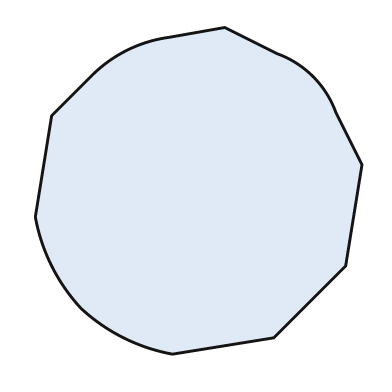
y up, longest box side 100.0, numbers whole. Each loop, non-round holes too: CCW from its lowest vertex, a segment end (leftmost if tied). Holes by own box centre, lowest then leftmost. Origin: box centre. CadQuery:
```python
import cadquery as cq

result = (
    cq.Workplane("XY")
    .moveTo(-8.0, -50.0)
    .lineTo(23.0, -45.0)
    .lineTo(45.0, -23.0)
    .lineTo(50.0, 8.0)
    .lineTo(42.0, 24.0)
    .threePointArc((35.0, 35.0), (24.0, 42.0))
    .lineTo(8.0, 50.0)
    .lineTo(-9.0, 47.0)
    .threePointArc((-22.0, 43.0), (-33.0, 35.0))
    .lineTo(-45.0, 23.0)
    .lineTo(-50.0, -8.0)
    .threePointArc((-45.0, -23.0), (-36.0, -36.0))
    .threePointArc((-23.0, -45.0), (-8.0, -50.0))
    .close()
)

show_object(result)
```